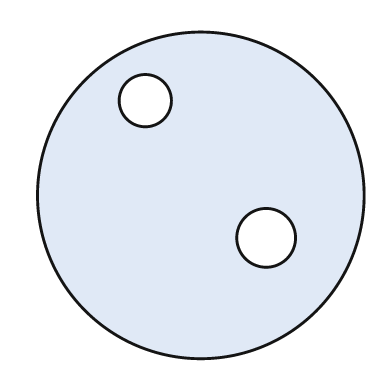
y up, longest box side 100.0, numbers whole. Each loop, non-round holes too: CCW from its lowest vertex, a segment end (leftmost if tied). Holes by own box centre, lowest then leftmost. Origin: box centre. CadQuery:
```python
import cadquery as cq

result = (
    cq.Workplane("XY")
    .moveTo(0.0, 0.0)
    .circle(50.0)
    .moveTo(20.0, -13.0)
    .circle(9.0)
    .moveTo(-17.0, 29.0)
    .circle(8.0)
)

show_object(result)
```